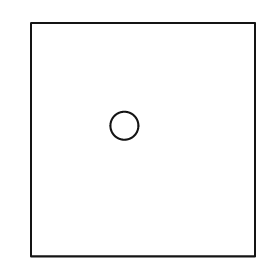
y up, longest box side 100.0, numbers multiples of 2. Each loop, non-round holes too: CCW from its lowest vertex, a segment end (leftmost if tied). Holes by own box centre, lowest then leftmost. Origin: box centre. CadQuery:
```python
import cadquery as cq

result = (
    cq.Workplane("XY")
    .moveTo(-48.0, -50.0)
    .lineTo(48.0, -50.0)
    .lineTo(48.0, 50.0)
    .lineTo(-48.0, 50.0)
    .close()
    .moveTo(-8.0, 6.0)
    .circle(6.0)
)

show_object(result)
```